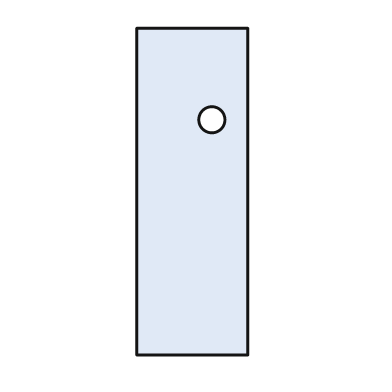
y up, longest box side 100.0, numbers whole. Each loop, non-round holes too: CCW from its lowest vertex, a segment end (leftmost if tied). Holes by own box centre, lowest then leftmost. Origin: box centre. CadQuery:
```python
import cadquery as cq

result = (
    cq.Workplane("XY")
    .moveTo(-17.0, -50.0)
    .lineTo(17.0, -50.0)
    .lineTo(17.0, 50.0)
    .lineTo(-17.0, 50.0)
    .close()
    .moveTo(6.0, 22.0)
    .circle(4.0)
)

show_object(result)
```